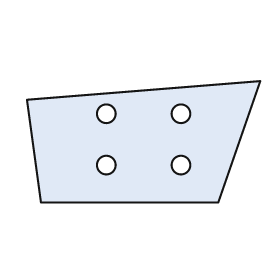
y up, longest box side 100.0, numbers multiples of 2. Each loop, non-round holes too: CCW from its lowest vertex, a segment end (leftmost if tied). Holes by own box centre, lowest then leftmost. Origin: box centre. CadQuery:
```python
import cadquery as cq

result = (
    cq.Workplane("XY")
    .moveTo(-44.0, -26.0)
    .lineTo(32.0, -26.0)
    .lineTo(50.0, 26.0)
    .lineTo(-50.0, 18.0)
    .close()
    .moveTo(-16.0, -10.0)
    .circle(4.0)
    .moveTo(16.0, -10.0)
    .circle(4.0)
    .moveTo(-16.0, 12.0)
    .circle(4.0)
    .moveTo(16.0, 12.0)
    .circle(4.0)
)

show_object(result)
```